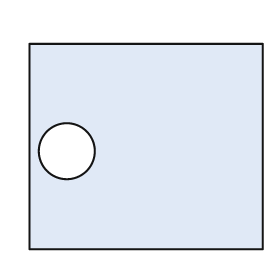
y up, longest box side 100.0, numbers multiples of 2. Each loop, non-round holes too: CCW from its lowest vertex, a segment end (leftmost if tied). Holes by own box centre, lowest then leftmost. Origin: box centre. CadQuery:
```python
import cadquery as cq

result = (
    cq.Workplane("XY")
    .moveTo(-50.0, -44.0)
    .lineTo(50.0, -44.0)
    .lineTo(50.0, 44.0)
    .lineTo(-50.0, 44.0)
    .close()
    .moveTo(-34.0, -2.0)
    .circle(12.0)
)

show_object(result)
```